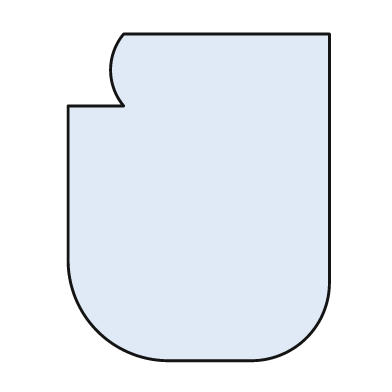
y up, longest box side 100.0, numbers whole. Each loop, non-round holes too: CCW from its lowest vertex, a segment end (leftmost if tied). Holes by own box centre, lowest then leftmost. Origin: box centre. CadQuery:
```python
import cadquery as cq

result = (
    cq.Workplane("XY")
    .moveTo(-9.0, -50.0)
    .lineTo(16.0, -50.0)
    .threePointArc((33.0, -43.0), (40.0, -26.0))
    .lineTo(40.0, 50.0)
    .lineTo(-23.0, 50.0)
    .threePointArc((-27.0, 39.0), (-23.0, 28.0))
    .lineTo(-40.0, 28.0)
    .lineTo(-40.0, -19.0)
    .threePointArc((-31.0, -41.0), (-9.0, -50.0))
    .close()
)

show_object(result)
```